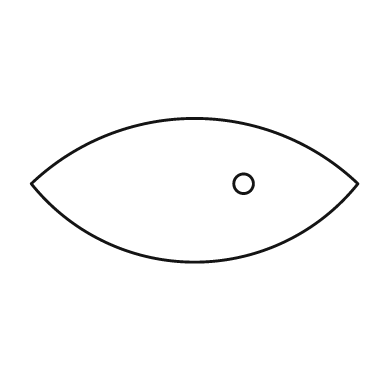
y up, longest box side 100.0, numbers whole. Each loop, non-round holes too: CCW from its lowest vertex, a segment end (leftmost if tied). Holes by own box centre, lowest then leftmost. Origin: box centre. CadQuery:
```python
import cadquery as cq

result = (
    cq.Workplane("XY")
    .moveTo(-50.0, 2.0)
    .threePointArc((0.0, -22.0), (50.0, 2.0))
    .threePointArc((0.0, 22.0), (-50.0, 2.0))
    .close()
    .moveTo(15.0, 2.0)
    .circle(3.0)
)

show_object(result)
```